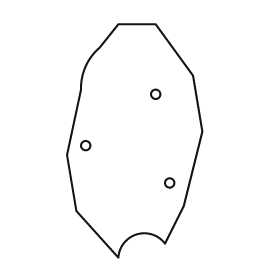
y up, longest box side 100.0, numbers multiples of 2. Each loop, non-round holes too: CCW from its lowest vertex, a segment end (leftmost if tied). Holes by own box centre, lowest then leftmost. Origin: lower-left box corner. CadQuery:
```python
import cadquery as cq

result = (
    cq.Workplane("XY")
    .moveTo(22.0, 0.0)
    .threePointArc((30.0, 10.0), (42.0, 6.0))
    .lineTo(50.0, 22.0)
    .lineTo(58.0, 54.0)
    .lineTo(54.0, 78.0)
    .lineTo(38.0, 100.0)
    .lineTo(22.0, 100.0)
    .lineTo(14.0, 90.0)
    .threePointArc((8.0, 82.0), (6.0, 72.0))
    .lineTo(0.0, 44.0)
    .lineTo(4.0, 20.0)
    .close()
    .moveTo(44.0, 32.0)
    .circle(2.0)
    .moveTo(8.0, 48.0)
    .circle(2.0)
    .moveTo(38.0, 70.0)
    .circle(2.0)
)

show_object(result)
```